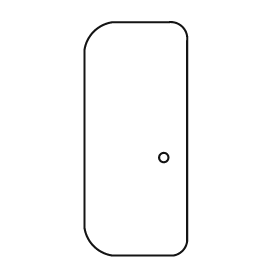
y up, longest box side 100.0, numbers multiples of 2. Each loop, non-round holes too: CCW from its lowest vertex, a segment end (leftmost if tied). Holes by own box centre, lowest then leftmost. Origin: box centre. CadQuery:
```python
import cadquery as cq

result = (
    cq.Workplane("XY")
    .moveTo(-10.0, -50.0)
    .lineTo(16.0, -50.0)
    .threePointArc((20.0, -48.0), (22.0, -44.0))
    .lineTo(22.0, 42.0)
    .threePointArc((20.0, 48.0), (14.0, 50.0))
    .lineTo(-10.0, 50.0)
    .threePointArc((-18.0, 46.0), (-22.0, 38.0))
    .lineTo(-22.0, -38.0)
    .threePointArc((-18.0, -46.0), (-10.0, -50.0))
    .close()
    .moveTo(12.0, -8.0)
    .circle(2.0)
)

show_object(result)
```